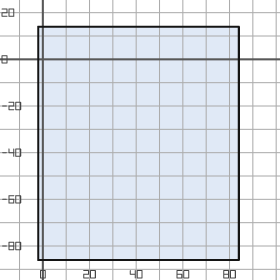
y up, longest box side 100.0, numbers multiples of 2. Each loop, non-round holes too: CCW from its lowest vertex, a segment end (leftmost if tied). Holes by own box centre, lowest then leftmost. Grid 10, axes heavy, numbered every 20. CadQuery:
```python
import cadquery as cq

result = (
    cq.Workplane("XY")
    .moveTo(-2.0, -86.0)
    .lineTo(84.0, -86.0)
    .lineTo(84.0, 14.0)
    .lineTo(-2.0, 14.0)
    .close()
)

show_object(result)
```